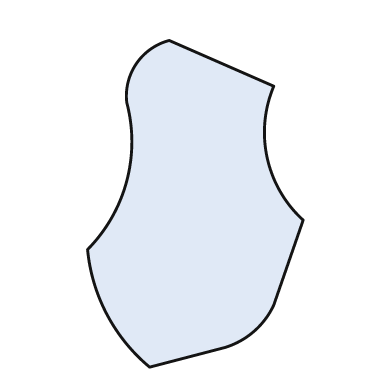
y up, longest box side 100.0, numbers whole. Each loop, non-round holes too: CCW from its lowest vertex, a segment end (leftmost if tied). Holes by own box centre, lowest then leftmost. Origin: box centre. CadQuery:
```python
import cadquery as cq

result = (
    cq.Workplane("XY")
    .moveTo(-14.0, -50.0)
    .lineTo(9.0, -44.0)
    .threePointArc((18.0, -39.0), (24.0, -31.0))
    .lineTo(33.0, -5.0)
    .threePointArc((22.0, 14.0), (24.0, 36.0))
    .lineTo(-8.0, 50.0)
    .threePointArc((-18.0, 43.0), (-21.0, 31.0))
    .threePointArc((-21.0, 7.0), (-33.0, -14.0))
    .threePointArc((-27.0, -34.0), (-14.0, -50.0))
    .close()
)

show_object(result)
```